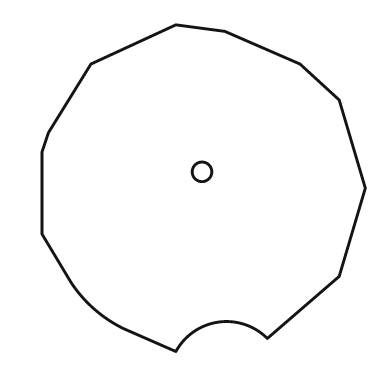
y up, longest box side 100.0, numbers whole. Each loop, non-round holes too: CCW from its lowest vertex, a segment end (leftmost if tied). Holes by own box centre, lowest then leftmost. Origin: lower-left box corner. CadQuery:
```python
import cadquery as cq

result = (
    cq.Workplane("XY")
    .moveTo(41.0, 0.0)
    .threePointArc((54.0, 9.0), (69.0, 4.0))
    .lineTo(91.0, 23.0)
    .lineTo(99.0, 50.0)
    .lineTo(91.0, 77.0)
    .lineTo(79.0, 88.0)
    .lineTo(56.0, 98.0)
    .lineTo(41.0, 100.0)
    .lineTo(15.0, 88.0)
    .lineTo(2.0, 67.0)
    .lineTo(0.0, 61.0)
    .lineTo(0.0, 36.0)
    .lineTo(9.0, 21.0)
    .threePointArc((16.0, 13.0), (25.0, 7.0))
    .close()
    .moveTo(49.0, 55.0)
    .circle(3.0)
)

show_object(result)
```